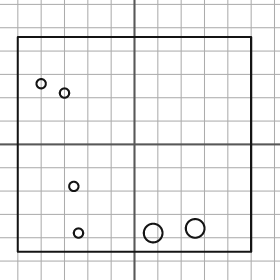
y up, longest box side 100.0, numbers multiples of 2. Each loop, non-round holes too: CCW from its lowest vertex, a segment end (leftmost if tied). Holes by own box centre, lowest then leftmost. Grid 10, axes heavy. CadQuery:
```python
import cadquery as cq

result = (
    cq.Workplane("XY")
    .moveTo(-50.0, -46.0)
    .lineTo(50.0, -46.0)
    .lineTo(50.0, 46.0)
    .lineTo(-50.0, 46.0)
    .close()
    .moveTo(-24.0, -38.0)
    .circle(2.0)
    .moveTo(8.0, -38.0)
    .circle(4.0)
    .moveTo(26.0, -36.0)
    .circle(4.0)
    .moveTo(-26.0, -18.0)
    .circle(2.0)
    .moveTo(-30.0, 22.0)
    .circle(2.0)
    .moveTo(-40.0, 26.0)
    .circle(2.0)
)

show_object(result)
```